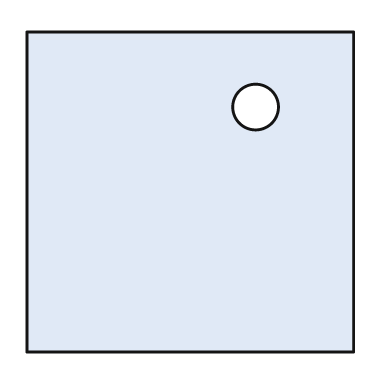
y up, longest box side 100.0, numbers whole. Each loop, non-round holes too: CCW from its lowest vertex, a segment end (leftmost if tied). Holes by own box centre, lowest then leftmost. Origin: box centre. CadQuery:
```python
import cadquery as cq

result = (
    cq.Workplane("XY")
    .moveTo(-50.0, -49.0)
    .lineTo(50.0, -49.0)
    .lineTo(50.0, 49.0)
    .lineTo(-50.0, 49.0)
    .close()
    .moveTo(20.0, 26.0)
    .circle(7.0)
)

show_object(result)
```